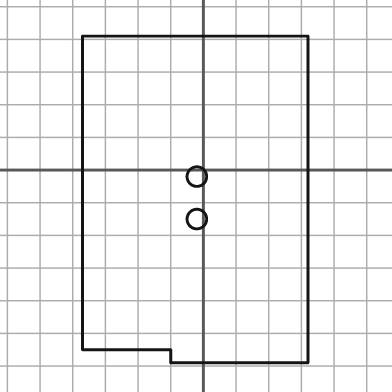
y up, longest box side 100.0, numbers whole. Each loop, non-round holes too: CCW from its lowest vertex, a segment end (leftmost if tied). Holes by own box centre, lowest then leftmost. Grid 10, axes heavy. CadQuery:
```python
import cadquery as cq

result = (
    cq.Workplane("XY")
    .moveTo(-10.0, -59.0)
    .lineTo(32.0, -59.0)
    .lineTo(32.0, 41.0)
    .lineTo(-37.0, 41.0)
    .lineTo(-37.0, -55.0)
    .lineTo(-10.0, -55.0)
    .close()
    .moveTo(-2.0, -15.0)
    .circle(3.0)
    .moveTo(-2.0, -2.0)
    .circle(3.0)
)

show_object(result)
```